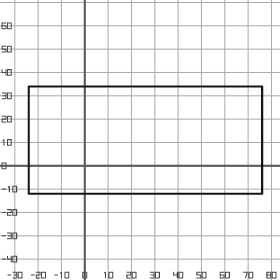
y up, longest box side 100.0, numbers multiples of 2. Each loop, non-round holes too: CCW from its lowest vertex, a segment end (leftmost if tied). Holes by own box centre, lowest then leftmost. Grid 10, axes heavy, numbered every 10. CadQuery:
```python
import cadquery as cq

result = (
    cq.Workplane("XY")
    .moveTo(-24.0, -12.0)
    .lineTo(76.0, -12.0)
    .lineTo(76.0, 34.0)
    .lineTo(-24.0, 34.0)
    .close()
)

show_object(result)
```